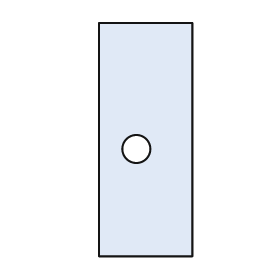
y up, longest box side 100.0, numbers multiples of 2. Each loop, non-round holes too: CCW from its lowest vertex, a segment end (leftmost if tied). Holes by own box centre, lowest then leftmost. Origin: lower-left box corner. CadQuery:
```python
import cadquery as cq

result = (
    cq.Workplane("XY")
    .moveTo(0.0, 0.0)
    .lineTo(40.0, 0.0)
    .lineTo(40.0, 100.0)
    .lineTo(0.0, 100.0)
    .close()
    .moveTo(16.0, 46.0)
    .circle(6.0)
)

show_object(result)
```